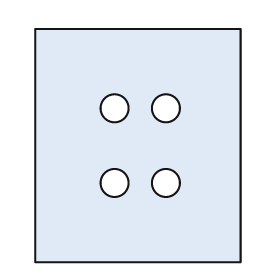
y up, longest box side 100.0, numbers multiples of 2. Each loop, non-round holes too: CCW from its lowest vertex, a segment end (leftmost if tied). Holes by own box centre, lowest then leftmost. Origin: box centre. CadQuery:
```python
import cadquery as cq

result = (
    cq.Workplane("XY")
    .moveTo(-44.0, -50.0)
    .lineTo(44.0, -50.0)
    .lineTo(44.0, 50.0)
    .lineTo(-44.0, 50.0)
    .close()
    .moveTo(-10.0, -16.0)
    .circle(6.0)
    .moveTo(12.0, -16.0)
    .circle(6.0)
    .moveTo(-10.0, 16.0)
    .circle(6.0)
    .moveTo(12.0, 16.0)
    .circle(6.0)
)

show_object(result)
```